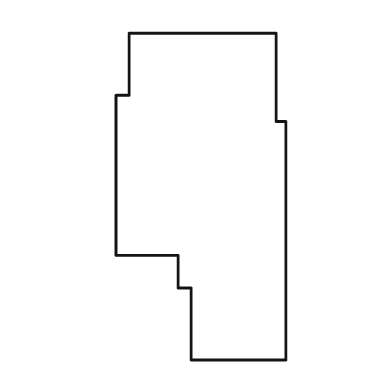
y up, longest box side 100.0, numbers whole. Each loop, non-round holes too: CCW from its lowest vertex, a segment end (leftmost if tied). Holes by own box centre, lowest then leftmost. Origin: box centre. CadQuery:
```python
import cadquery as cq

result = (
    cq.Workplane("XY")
    .moveTo(-3.0, -50.0)
    .lineTo(26.0, -50.0)
    .lineTo(26.0, 23.0)
    .lineTo(23.0, 23.0)
    .lineTo(23.0, 50.0)
    .lineTo(-22.0, 50.0)
    .lineTo(-22.0, 31.0)
    .lineTo(-26.0, 31.0)
    .lineTo(-26.0, -18.0)
    .lineTo(-7.0, -18.0)
    .lineTo(-7.0, -28.0)
    .lineTo(-3.0, -28.0)
    .close()
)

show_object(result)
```